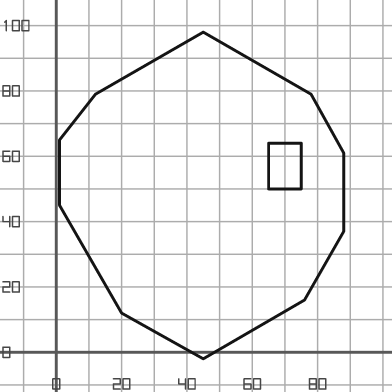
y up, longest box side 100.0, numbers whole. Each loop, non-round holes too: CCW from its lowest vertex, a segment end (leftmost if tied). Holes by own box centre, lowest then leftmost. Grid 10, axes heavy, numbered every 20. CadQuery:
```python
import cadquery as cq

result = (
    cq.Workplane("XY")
    .moveTo(45.0, -2.0)
    .lineTo(76.0, 16.0)
    .lineTo(88.0, 37.0)
    .lineTo(88.0, 61.0)
    .lineTo(78.0, 79.0)
    .lineTo(45.0, 98.0)
    .lineTo(12.0, 79.0)
    .lineTo(1.0, 65.0)
    .lineTo(1.0, 45.0)
    .lineTo(20.0, 12.0)
    .close()
    .moveTo(65.0, 50.0)
    .lineTo(75.0, 50.0)
    .lineTo(75.0, 64.0)
    .lineTo(65.0, 64.0)
    .close()
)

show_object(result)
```